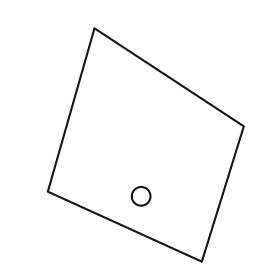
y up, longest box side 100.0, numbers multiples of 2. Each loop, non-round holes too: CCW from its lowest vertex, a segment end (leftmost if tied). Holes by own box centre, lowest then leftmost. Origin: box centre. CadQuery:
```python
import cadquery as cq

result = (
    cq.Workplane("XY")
    .moveTo(24.0, -50.0)
    .lineTo(42.0, 8.0)
    .lineTo(-22.0, 50.0)
    .lineTo(-42.0, -20.0)
    .close()
    .moveTo(-2.0, -22.0)
    .circle(4.0)
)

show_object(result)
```